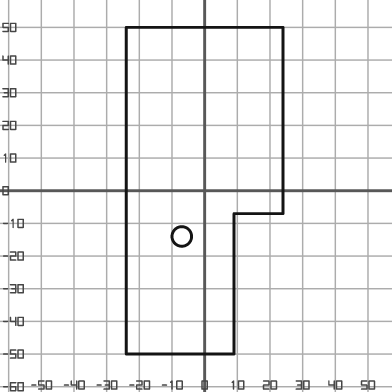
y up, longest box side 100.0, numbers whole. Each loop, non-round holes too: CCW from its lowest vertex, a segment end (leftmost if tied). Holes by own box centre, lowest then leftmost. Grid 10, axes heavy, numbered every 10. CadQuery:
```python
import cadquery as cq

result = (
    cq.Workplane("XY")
    .moveTo(-24.0, -50.0)
    .lineTo(9.0, -50.0)
    .lineTo(9.0, -7.0)
    .lineTo(24.0, -7.0)
    .lineTo(24.0, 50.0)
    .lineTo(-24.0, 50.0)
    .close()
    .moveTo(-7.0, -14.0)
    .circle(3.0)
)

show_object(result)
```